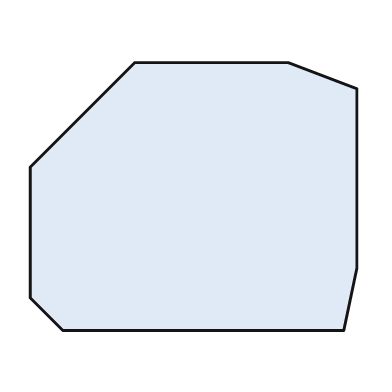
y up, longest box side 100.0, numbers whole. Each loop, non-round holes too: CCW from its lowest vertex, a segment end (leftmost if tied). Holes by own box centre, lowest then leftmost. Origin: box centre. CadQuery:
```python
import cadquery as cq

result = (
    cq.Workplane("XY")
    .moveTo(-40.0, -41.0)
    .lineTo(46.0, -41.0)
    .lineTo(50.0, -22.0)
    .lineTo(50.0, 33.0)
    .lineTo(29.0, 41.0)
    .lineTo(-18.0, 41.0)
    .lineTo(-50.0, 9.0)
    .lineTo(-50.0, -31.0)
    .close()
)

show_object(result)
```